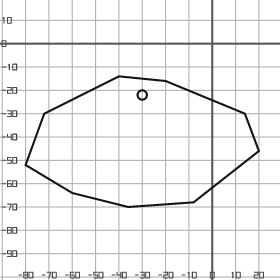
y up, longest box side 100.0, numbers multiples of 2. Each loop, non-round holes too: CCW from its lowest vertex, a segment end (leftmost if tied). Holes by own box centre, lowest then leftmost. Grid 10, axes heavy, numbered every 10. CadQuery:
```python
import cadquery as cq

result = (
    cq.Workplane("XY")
    .moveTo(-36.0, -70.0)
    .lineTo(-8.0, -68.0)
    .lineTo(20.0, -46.0)
    .lineTo(14.0, -30.0)
    .lineTo(-20.0, -16.0)
    .lineTo(-40.0, -14.0)
    .lineTo(-72.0, -30.0)
    .lineTo(-80.0, -52.0)
    .lineTo(-60.0, -64.0)
    .close()
    .moveTo(-30.0, -22.0)
    .circle(2.0)
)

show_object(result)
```